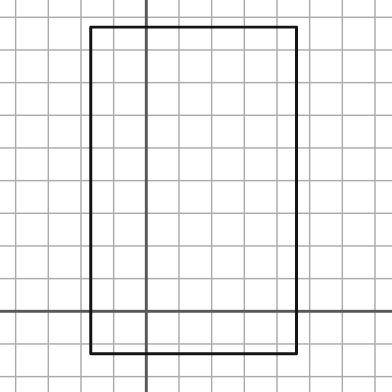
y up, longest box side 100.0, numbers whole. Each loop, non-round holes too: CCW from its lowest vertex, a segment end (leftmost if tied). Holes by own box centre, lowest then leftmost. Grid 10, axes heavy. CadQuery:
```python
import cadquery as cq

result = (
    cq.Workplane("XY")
    .moveTo(-17.0, -13.0)
    .lineTo(46.0, -13.0)
    .lineTo(46.0, 87.0)
    .lineTo(-17.0, 87.0)
    .close()
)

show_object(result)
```